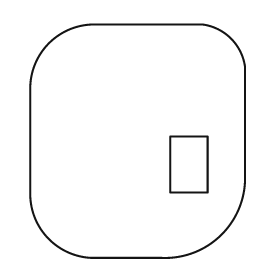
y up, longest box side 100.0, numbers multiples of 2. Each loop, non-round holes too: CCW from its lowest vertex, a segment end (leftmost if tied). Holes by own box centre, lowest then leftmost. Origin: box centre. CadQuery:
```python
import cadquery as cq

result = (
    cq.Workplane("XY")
    .moveTo(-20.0, -50.0)
    .lineTo(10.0, -50.0)
    .threePointArc((36.0, -40.0), (46.0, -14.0))
    .lineTo(46.0, 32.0)
    .threePointArc((40.0, 44.0), (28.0, 50.0))
    .lineTo(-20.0, 50.0)
    .threePointArc((-38.0, 42.0), (-46.0, 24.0))
    .lineTo(-46.0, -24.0)
    .threePointArc((-38.0, -42.0), (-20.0, -50.0))
    .close()
    .moveTo(14.0, -22.0)
    .lineTo(30.0, -22.0)
    .lineTo(30.0, 2.0)
    .lineTo(14.0, 2.0)
    .close()
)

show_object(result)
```